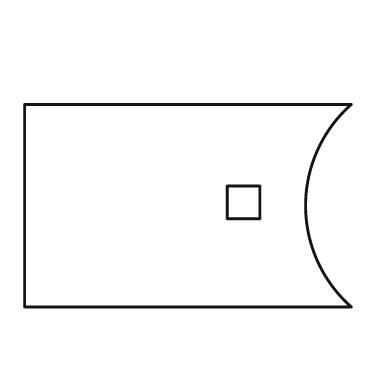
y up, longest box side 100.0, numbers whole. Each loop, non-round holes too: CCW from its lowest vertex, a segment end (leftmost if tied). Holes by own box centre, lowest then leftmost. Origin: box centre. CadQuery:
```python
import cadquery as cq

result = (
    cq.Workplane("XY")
    .moveTo(-50.0, -31.0)
    .lineTo(50.0, -31.0)
    .threePointArc((36.0, 0.0), (50.0, 31.0))
    .lineTo(-50.0, 31.0)
    .close()
    .moveTo(12.0, -4.0)
    .lineTo(22.0, -4.0)
    .lineTo(22.0, 6.0)
    .lineTo(12.0, 6.0)
    .close()
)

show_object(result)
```